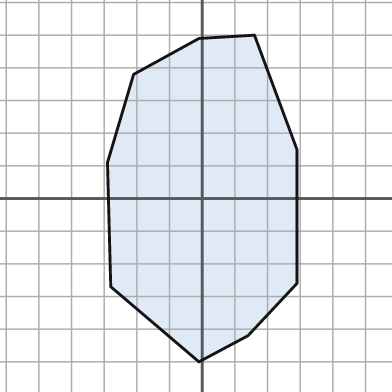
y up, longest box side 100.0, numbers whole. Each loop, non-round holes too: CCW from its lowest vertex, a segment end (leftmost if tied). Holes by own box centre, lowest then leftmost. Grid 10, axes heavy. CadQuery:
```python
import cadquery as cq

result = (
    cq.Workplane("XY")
    .moveTo(-1.0, -50.0)
    .lineTo(14.0, -42.0)
    .lineTo(29.0, -26.0)
    .lineTo(29.0, 15.0)
    .lineTo(16.0, 50.0)
    .lineTo(-1.0, 49.0)
    .lineTo(-21.0, 38.0)
    .lineTo(-29.0, 11.0)
    .lineTo(-28.0, -27.0)
    .close()
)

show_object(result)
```